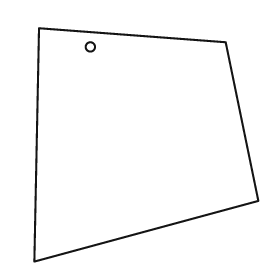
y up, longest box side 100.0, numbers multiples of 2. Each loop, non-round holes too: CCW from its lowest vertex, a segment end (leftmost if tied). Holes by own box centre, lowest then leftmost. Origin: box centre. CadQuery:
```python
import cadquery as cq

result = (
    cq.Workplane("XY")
    .moveTo(-48.0, -50.0)
    .lineTo(48.0, -24.0)
    .lineTo(34.0, 44.0)
    .lineTo(-46.0, 50.0)
    .close()
    .moveTo(-24.0, 42.0)
    .circle(2.0)
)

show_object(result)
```